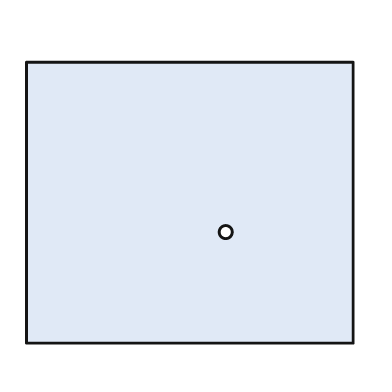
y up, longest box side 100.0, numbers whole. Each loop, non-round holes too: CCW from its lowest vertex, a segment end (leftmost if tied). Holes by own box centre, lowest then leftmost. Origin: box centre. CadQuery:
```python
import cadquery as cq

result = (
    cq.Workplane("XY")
    .moveTo(-50.0, -43.0)
    .lineTo(50.0, -43.0)
    .lineTo(50.0, 43.0)
    .lineTo(-50.0, 43.0)
    .close()
    .moveTo(11.0, -9.0)
    .circle(2.0)
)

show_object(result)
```